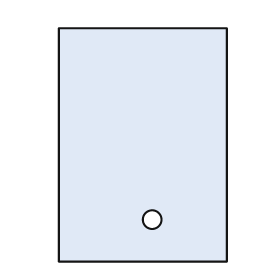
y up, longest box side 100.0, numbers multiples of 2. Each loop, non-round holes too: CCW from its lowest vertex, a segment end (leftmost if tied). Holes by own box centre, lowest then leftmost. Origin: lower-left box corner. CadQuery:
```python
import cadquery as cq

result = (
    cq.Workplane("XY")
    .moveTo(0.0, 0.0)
    .lineTo(72.0, 0.0)
    .lineTo(72.0, 100.0)
    .lineTo(0.0, 100.0)
    .close()
    .moveTo(40.0, 18.0)
    .circle(4.0)
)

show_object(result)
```